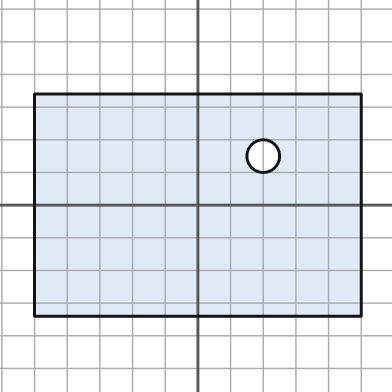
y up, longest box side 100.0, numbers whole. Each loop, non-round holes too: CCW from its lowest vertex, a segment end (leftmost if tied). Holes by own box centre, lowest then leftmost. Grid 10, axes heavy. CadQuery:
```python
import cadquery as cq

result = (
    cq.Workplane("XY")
    .moveTo(-50.0, -34.0)
    .lineTo(50.0, -34.0)
    .lineTo(50.0, 34.0)
    .lineTo(-50.0, 34.0)
    .close()
    .moveTo(20.0, 15.0)
    .circle(5.0)
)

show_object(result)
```